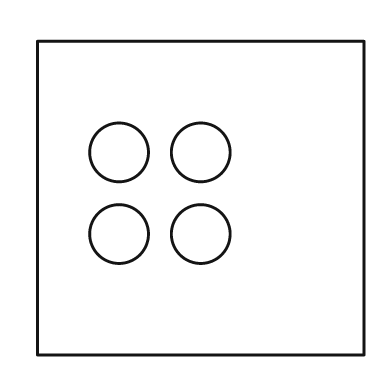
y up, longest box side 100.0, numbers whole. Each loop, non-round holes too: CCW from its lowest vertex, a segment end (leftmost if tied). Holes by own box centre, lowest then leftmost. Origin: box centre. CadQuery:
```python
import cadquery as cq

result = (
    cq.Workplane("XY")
    .moveTo(-50.0, -48.0)
    .lineTo(50.0, -48.0)
    .lineTo(50.0, 48.0)
    .lineTo(-50.0, 48.0)
    .close()
    .moveTo(-25.0, -11.0)
    .circle(9.0)
    .moveTo(0.0, -11.0)
    .circle(9.0)
    .moveTo(-25.0, 14.0)
    .circle(9.0)
    .moveTo(0.0, 14.0)
    .circle(9.0)
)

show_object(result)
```